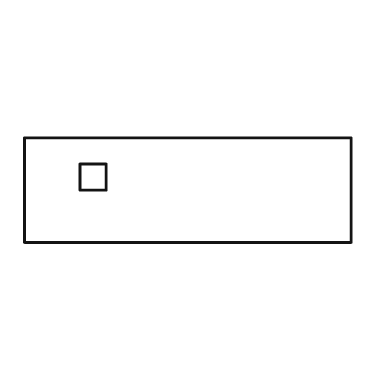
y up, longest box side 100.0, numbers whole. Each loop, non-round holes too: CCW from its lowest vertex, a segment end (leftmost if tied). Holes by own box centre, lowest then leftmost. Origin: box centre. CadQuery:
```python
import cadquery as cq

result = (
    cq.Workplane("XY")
    .moveTo(-50.0, -16.0)
    .lineTo(50.0, -16.0)
    .lineTo(50.0, 16.0)
    .lineTo(-50.0, 16.0)
    .close()
    .moveTo(-33.0, 0.0)
    .lineTo(-25.0, 0.0)
    .lineTo(-25.0, 8.0)
    .lineTo(-33.0, 8.0)
    .close()
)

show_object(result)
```